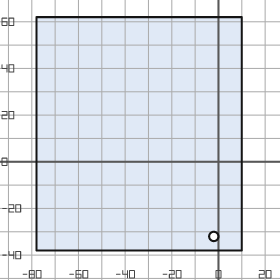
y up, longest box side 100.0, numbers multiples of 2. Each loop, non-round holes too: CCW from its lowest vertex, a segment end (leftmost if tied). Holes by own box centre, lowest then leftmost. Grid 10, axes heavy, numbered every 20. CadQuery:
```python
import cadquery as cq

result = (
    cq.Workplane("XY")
    .moveTo(-78.0, -38.0)
    .lineTo(10.0, -38.0)
    .lineTo(10.0, 62.0)
    .lineTo(-78.0, 62.0)
    .close()
    .moveTo(-2.0, -32.0)
    .circle(2.0)
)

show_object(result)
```